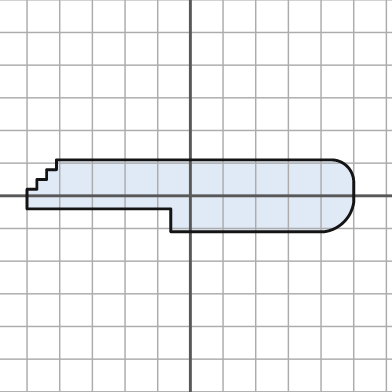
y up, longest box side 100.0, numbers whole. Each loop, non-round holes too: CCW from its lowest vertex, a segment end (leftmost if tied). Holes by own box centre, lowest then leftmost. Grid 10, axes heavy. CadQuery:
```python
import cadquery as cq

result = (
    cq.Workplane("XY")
    .moveTo(-6.0, -11.0)
    .lineTo(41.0, -11.0)
    .threePointArc((47.0, -8.0), (50.0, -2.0))
    .lineTo(50.0, 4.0)
    .threePointArc((48.0, 9.0), (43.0, 11.0))
    .lineTo(-41.0, 11.0)
    .lineTo(-41.0, 8.0)
    .lineTo(-44.0, 8.0)
    .lineTo(-44.0, 5.0)
    .lineTo(-47.0, 5.0)
    .lineTo(-47.0, 2.0)
    .lineTo(-50.0, 2.0)
    .lineTo(-50.0, -4.0)
    .lineTo(-6.0, -4.0)
    .close()
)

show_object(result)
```